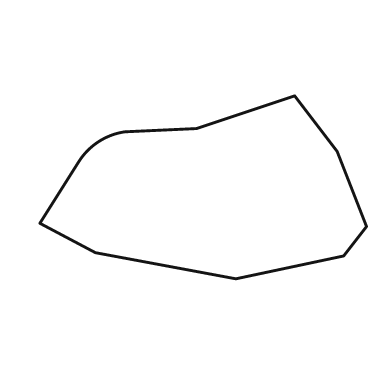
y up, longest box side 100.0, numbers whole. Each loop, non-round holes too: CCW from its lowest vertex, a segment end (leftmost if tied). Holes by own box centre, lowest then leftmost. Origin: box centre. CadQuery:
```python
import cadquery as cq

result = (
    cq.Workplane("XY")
    .moveTo(10.0, -28.0)
    .lineTo(43.0, -21.0)
    .lineTo(50.0, -12.0)
    .lineTo(41.0, 11.0)
    .lineTo(28.0, 28.0)
    .lineTo(-2.0, 18.0)
    .lineTo(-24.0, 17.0)
    .threePointArc((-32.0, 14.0), (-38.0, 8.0))
    .lineTo(-50.0, -11.0)
    .lineTo(-33.0, -20.0)
    .close()
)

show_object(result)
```